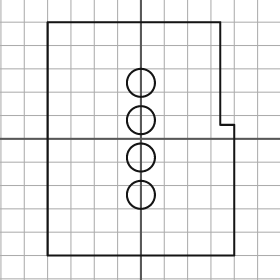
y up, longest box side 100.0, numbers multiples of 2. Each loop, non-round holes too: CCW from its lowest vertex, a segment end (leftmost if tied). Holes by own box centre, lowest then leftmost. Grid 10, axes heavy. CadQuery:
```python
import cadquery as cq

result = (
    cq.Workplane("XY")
    .moveTo(-40.0, -50.0)
    .lineTo(40.0, -50.0)
    .lineTo(40.0, 6.0)
    .lineTo(34.0, 6.0)
    .lineTo(34.0, 50.0)
    .lineTo(-40.0, 50.0)
    .close()
    .moveTo(0.0, -24.0)
    .circle(6.0)
    .moveTo(0.0, -8.0)
    .circle(6.0)
    .moveTo(0.0, 8.0)
    .circle(6.0)
    .moveTo(0.0, 24.0)
    .circle(6.0)
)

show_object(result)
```